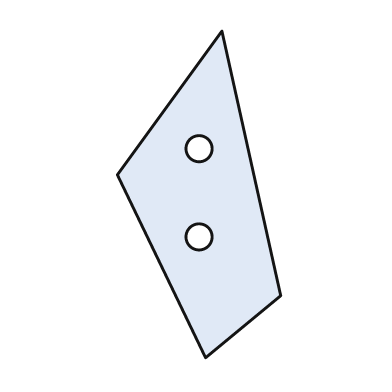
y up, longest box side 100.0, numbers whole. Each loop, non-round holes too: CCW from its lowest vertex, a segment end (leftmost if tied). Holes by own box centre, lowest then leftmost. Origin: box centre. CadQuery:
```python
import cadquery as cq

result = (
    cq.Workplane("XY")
    .moveTo(2.0, -50.0)
    .lineTo(25.0, -31.0)
    .lineTo(7.0, 50.0)
    .lineTo(-25.0, 6.0)
    .close()
    .moveTo(0.0, -13.0)
    .circle(4.0)
    .moveTo(0.0, 14.0)
    .circle(4.0)
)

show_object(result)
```